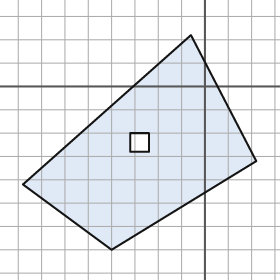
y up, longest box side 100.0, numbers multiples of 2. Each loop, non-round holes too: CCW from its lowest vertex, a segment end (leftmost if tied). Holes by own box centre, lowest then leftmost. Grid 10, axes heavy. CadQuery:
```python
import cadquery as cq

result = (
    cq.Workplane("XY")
    .moveTo(-40.0, -70.0)
    .lineTo(22.0, -32.0)
    .lineTo(-6.0, 22.0)
    .lineTo(-78.0, -42.0)
    .close()
    .moveTo(-32.0, -28.0)
    .lineTo(-24.0, -28.0)
    .lineTo(-24.0, -20.0)
    .lineTo(-32.0, -20.0)
    .close()
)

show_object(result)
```